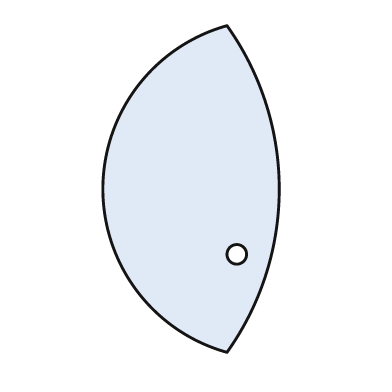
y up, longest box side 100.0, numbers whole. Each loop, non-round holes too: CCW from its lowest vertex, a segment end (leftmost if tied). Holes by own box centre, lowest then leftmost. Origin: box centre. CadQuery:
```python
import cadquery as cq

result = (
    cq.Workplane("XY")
    .moveTo(11.0, -50.0)
    .threePointArc((27.0, 0.0), (11.0, 50.0))
    .threePointArc((-27.0, 0.0), (11.0, -50.0))
    .close()
    .moveTo(14.0, -20.0)
    .circle(3.0)
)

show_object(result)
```